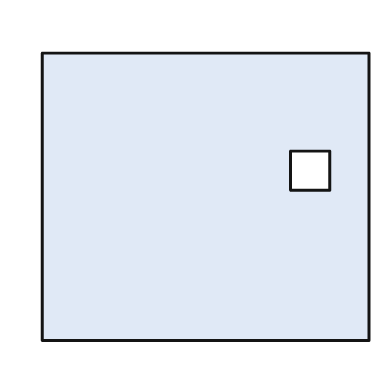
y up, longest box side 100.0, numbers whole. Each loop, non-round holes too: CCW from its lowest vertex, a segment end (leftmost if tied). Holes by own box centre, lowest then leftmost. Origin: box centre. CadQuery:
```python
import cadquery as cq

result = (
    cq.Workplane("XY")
    .moveTo(-50.0, -44.0)
    .lineTo(50.0, -44.0)
    .lineTo(50.0, 44.0)
    .lineTo(-50.0, 44.0)
    .close()
    .moveTo(26.0, 2.0)
    .lineTo(38.0, 2.0)
    .lineTo(38.0, 14.0)
    .lineTo(26.0, 14.0)
    .close()
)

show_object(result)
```